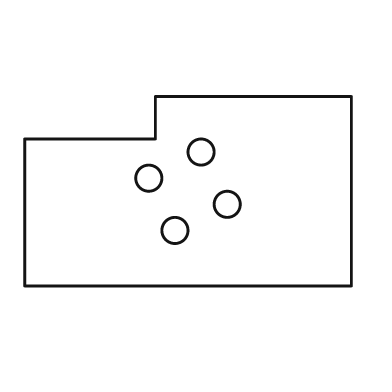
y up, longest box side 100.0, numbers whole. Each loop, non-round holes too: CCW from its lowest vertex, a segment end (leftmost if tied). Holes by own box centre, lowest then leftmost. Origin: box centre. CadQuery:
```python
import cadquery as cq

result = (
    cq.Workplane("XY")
    .moveTo(-50.0, -29.0)
    .lineTo(50.0, -29.0)
    .lineTo(50.0, 29.0)
    .lineTo(-10.0, 29.0)
    .lineTo(-10.0, 16.0)
    .lineTo(-50.0, 16.0)
    .close()
    .moveTo(-4.0, -12.0)
    .circle(4.0)
    .moveTo(12.0, -4.0)
    .circle(4.0)
    .moveTo(-12.0, 4.0)
    .circle(4.0)
    .moveTo(4.0, 12.0)
    .circle(4.0)
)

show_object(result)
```